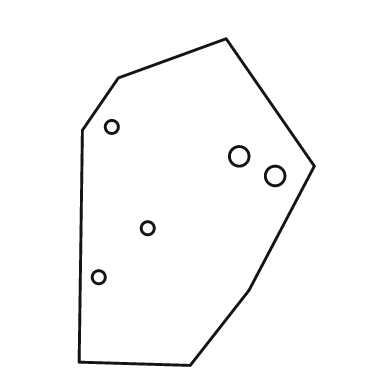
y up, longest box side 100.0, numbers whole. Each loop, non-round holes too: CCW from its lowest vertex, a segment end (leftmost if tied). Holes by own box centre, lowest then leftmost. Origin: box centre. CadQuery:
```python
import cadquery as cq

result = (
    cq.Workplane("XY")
    .moveTo(-2.0, -50.0)
    .lineTo(16.0, -27.0)
    .lineTo(36.0, 11.0)
    .lineTo(9.0, 50.0)
    .lineTo(-24.0, 38.0)
    .lineTo(-35.0, 22.0)
    .lineTo(-36.0, -49.0)
    .close()
    .moveTo(-30.0, -23.0)
    .circle(2.0)
    .moveTo(-15.0, -8.0)
    .circle(2.0)
    .moveTo(24.0, 8.0)
    .circle(3.0)
    .moveTo(13.0, 14.0)
    .circle(3.0)
    .moveTo(-26.0, 23.0)
    .circle(2.0)
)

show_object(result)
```